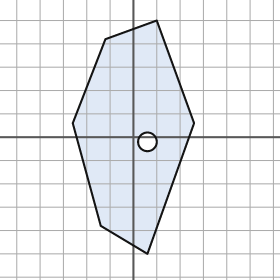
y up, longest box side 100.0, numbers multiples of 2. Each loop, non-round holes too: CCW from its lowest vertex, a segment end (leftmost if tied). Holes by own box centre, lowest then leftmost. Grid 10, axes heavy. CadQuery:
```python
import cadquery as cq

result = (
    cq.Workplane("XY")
    .moveTo(6.0, -50.0)
    .lineTo(26.0, 6.0)
    .lineTo(10.0, 50.0)
    .lineTo(-12.0, 42.0)
    .lineTo(-26.0, 6.0)
    .lineTo(-14.0, -38.0)
    .close()
    .moveTo(6.0, -2.0)
    .circle(4.0)
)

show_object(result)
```